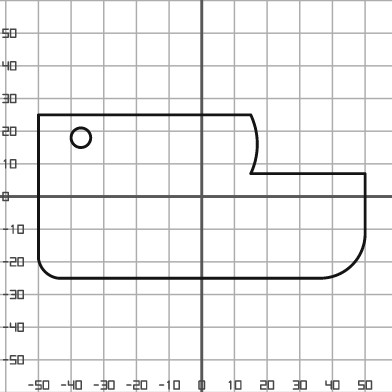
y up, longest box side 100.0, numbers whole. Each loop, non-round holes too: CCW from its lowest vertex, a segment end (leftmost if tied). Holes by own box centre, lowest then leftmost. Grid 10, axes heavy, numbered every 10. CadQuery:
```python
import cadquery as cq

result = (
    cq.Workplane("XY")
    .moveTo(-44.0, -25.0)
    .lineTo(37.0, -25.0)
    .threePointArc((46.0, -21.0), (50.0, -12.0))
    .lineTo(50.0, 7.0)
    .lineTo(15.0, 7.0)
    .threePointArc((17.0, 16.0), (15.0, 25.0))
    .lineTo(-50.0, 25.0)
    .lineTo(-50.0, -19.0)
    .threePointArc((-48.0, -23.0), (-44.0, -25.0))
    .close()
    .moveTo(-37.0, 18.0)
    .circle(3.0)
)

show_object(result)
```